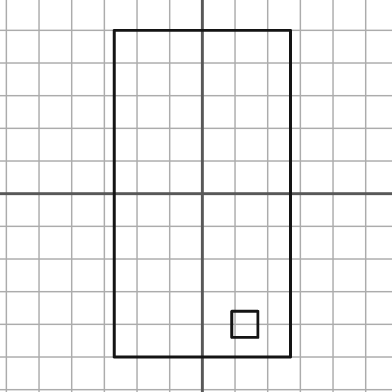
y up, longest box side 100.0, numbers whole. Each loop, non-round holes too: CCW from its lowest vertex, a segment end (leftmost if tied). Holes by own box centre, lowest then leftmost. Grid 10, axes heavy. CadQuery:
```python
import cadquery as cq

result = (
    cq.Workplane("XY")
    .moveTo(-27.0, -50.0)
    .lineTo(27.0, -50.0)
    .lineTo(27.0, 50.0)
    .lineTo(-27.0, 50.0)
    .close()
    .moveTo(9.0, -44.0)
    .lineTo(17.0, -44.0)
    .lineTo(17.0, -36.0)
    .lineTo(9.0, -36.0)
    .close()
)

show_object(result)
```